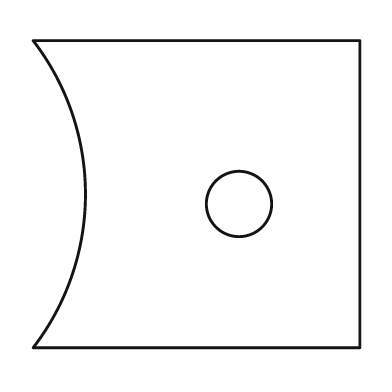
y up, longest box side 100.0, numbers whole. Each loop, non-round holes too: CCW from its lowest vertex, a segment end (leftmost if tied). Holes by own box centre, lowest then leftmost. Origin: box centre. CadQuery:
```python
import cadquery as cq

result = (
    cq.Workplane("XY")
    .moveTo(-50.0, -47.0)
    .lineTo(50.0, -47.0)
    .lineTo(50.0, 47.0)
    .lineTo(-50.0, 47.0)
    .threePointArc((-34.0, 0.0), (-50.0, -47.0))
    .close()
    .moveTo(13.0, -3.0)
    .circle(10.0)
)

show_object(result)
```